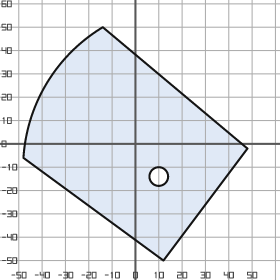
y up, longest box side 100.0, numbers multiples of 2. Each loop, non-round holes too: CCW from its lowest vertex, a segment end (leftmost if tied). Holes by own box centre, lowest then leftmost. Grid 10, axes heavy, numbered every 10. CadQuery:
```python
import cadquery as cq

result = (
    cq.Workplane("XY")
    .moveTo(12.0, -50.0)
    .lineTo(48.0, -2.0)
    .lineTo(-14.0, 50.0)
    .threePointArc((-38.0, 26.0), (-48.0, -6.0))
    .close()
    .moveTo(10.0, -14.0)
    .circle(4.0)
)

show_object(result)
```